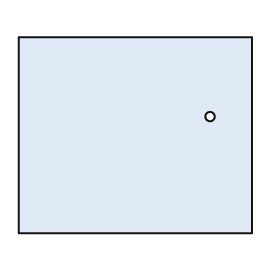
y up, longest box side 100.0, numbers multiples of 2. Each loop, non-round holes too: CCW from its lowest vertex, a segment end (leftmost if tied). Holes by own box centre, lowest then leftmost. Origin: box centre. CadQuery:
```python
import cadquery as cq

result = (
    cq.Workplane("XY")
    .moveTo(-50.0, -42.0)
    .lineTo(50.0, -42.0)
    .lineTo(50.0, 42.0)
    .lineTo(-50.0, 42.0)
    .close()
    .moveTo(32.0, 8.0)
    .circle(2.0)
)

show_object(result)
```